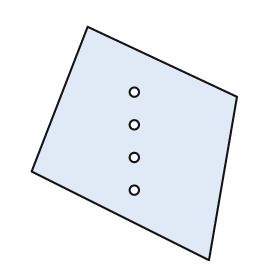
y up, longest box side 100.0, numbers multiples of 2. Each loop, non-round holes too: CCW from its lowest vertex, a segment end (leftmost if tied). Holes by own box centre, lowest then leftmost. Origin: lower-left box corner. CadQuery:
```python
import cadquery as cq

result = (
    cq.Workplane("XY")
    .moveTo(76.0, 0.0)
    .lineTo(88.0, 70.0)
    .lineTo(24.0, 100.0)
    .lineTo(0.0, 38.0)
    .close()
    .moveTo(44.0, 30.0)
    .circle(2.0)
    .moveTo(44.0, 44.0)
    .circle(2.0)
    .moveTo(44.0, 58.0)
    .circle(2.0)
    .moveTo(44.0, 72.0)
    .circle(2.0)
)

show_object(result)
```